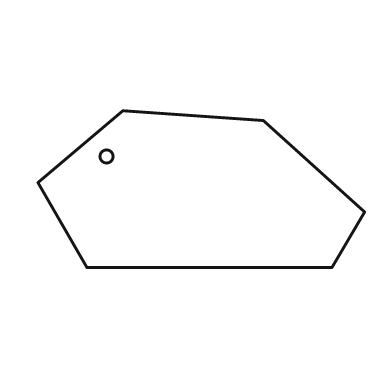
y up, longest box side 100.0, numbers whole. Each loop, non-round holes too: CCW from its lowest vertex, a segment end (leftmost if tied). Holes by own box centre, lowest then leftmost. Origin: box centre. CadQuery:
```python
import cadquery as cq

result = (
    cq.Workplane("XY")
    .moveTo(-35.0, -24.0)
    .lineTo(40.0, -24.0)
    .lineTo(50.0, -7.0)
    .lineTo(19.0, 21.0)
    .lineTo(-24.0, 24.0)
    .lineTo(-50.0, 2.0)
    .close()
    .moveTo(-29.0, 10.0)
    .circle(2.0)
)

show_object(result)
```